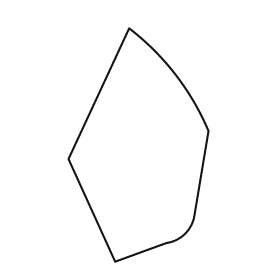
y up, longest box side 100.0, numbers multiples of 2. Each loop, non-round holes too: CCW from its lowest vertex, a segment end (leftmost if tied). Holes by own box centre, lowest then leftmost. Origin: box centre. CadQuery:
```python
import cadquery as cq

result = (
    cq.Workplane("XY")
    .moveTo(-10.0, -50.0)
    .lineTo(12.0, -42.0)
    .threePointArc((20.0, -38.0), (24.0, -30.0))
    .lineTo(30.0, 6.0)
    .threePointArc((16.0, 30.0), (-4.0, 50.0))
    .lineTo(-30.0, -6.0)
    .close()
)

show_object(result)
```